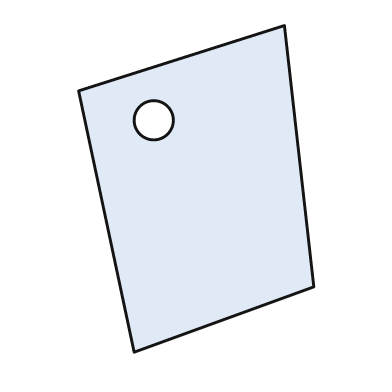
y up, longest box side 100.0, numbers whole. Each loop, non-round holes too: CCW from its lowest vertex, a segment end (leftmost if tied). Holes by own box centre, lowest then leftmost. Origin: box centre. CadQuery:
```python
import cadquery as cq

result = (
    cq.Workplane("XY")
    .moveTo(-19.0, -50.0)
    .lineTo(36.0, -30.0)
    .lineTo(27.0, 50.0)
    .lineTo(-36.0, 30.0)
    .close()
    .moveTo(-13.0, 21.0)
    .circle(6.0)
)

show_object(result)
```